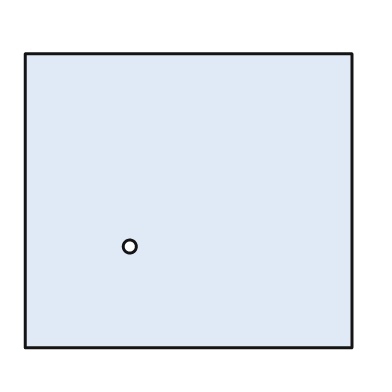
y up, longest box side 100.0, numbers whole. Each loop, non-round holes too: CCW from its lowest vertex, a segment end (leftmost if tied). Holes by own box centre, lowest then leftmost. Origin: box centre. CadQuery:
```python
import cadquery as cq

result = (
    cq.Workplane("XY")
    .moveTo(-50.0, -45.0)
    .lineTo(50.0, -45.0)
    .lineTo(50.0, 45.0)
    .lineTo(-50.0, 45.0)
    .close()
    .moveTo(-18.0, -14.0)
    .circle(2.0)
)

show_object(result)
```